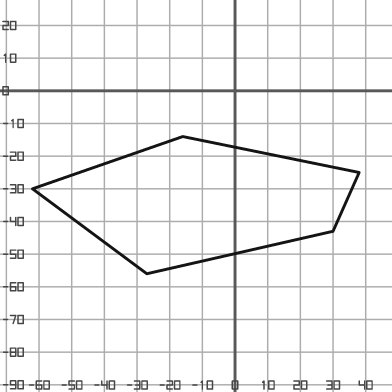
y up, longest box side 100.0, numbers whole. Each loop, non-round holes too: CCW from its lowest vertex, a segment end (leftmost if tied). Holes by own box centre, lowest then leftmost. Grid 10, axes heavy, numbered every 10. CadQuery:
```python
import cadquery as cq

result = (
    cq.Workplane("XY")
    .moveTo(-27.0, -56.0)
    .lineTo(30.0, -43.0)
    .lineTo(38.0, -25.0)
    .lineTo(-16.0, -14.0)
    .lineTo(-62.0, -30.0)
    .close()
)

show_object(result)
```